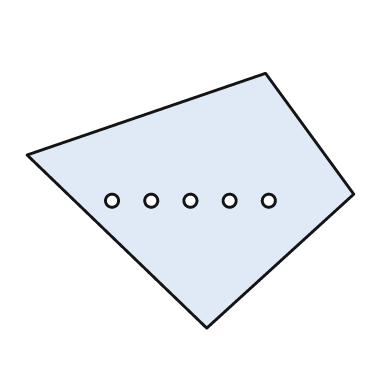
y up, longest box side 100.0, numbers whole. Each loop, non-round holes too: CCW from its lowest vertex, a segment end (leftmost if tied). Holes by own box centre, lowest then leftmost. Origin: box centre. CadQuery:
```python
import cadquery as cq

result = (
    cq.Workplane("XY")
    .moveTo(5.0, -39.0)
    .lineTo(50.0, 2.0)
    .lineTo(23.0, 39.0)
    .lineTo(-50.0, 14.0)
    .close()
    .moveTo(-24.0, 0.0)
    .circle(2.0)
    .moveTo(-12.0, 0.0)
    .circle(2.0)
    .moveTo(0.0, 0.0)
    .circle(2.0)
    .moveTo(12.0, 0.0)
    .circle(2.0)
    .moveTo(24.0, 0.0)
    .circle(2.0)
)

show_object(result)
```